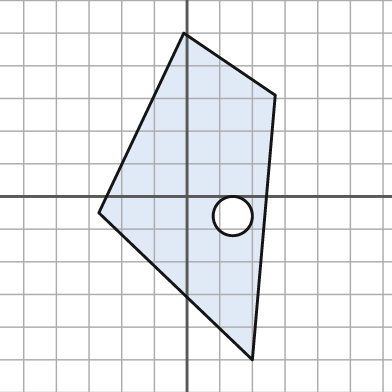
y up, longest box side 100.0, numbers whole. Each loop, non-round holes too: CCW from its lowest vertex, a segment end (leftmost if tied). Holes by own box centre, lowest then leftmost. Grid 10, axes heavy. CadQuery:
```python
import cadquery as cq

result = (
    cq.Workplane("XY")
    .moveTo(20.0, -50.0)
    .lineTo(27.0, 31.0)
    .lineTo(-1.0, 50.0)
    .lineTo(-27.0, -5.0)
    .close()
    .moveTo(14.0, -6.0)
    .circle(6.0)
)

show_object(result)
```